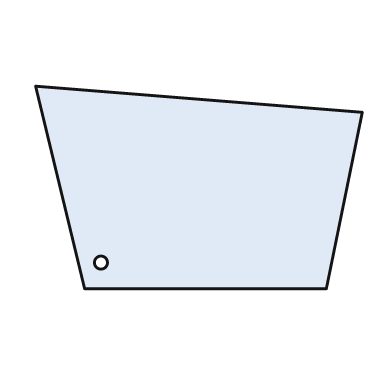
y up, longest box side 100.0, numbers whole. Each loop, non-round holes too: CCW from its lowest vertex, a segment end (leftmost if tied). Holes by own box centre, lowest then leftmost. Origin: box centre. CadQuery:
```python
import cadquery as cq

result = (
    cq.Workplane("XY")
    .moveTo(-35.0, -31.0)
    .lineTo(39.0, -31.0)
    .lineTo(50.0, 23.0)
    .lineTo(-50.0, 31.0)
    .close()
    .moveTo(-30.0, -23.0)
    .circle(2.0)
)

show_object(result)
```